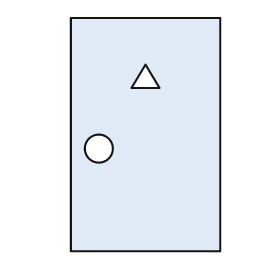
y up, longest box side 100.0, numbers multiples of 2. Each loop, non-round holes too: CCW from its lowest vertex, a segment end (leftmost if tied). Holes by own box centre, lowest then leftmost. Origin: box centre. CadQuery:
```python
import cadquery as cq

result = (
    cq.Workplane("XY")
    .moveTo(-32.0, -50.0)
    .lineTo(32.0, -50.0)
    .lineTo(32.0, 50.0)
    .lineTo(-32.0, 50.0)
    .close()
    .moveTo(-20.0, -6.0)
    .circle(6.0)
    .moveTo(-6.0, 20.0)
    .lineTo(6.0, 20.0)
    .lineTo(0.0, 30.0)
    .close()
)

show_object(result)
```